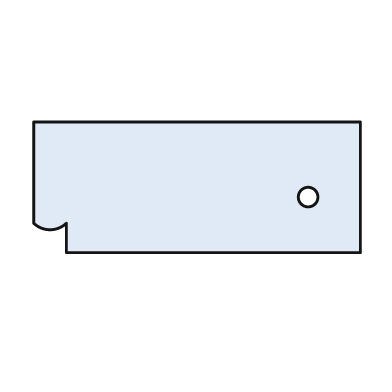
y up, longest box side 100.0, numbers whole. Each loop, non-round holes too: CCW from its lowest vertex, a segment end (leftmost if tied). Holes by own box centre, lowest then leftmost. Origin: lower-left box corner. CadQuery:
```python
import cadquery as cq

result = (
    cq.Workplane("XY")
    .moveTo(10.0, 0.0)
    .lineTo(100.0, 0.0)
    .lineTo(100.0, 40.0)
    .lineTo(0.0, 40.0)
    .lineTo(0.0, 9.0)
    .threePointArc((5.0, 7.0), (10.0, 9.0))
    .close()
    .moveTo(84.0, 17.0)
    .circle(3.0)
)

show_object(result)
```